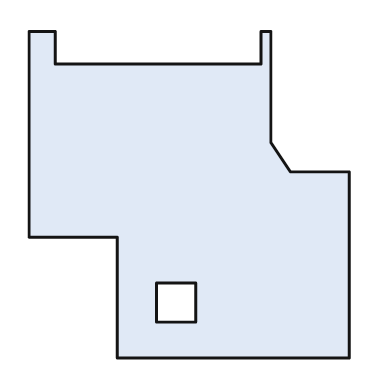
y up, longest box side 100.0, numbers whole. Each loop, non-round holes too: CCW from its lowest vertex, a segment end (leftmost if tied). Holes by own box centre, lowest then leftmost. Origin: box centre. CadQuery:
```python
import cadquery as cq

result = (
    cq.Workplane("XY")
    .moveTo(-22.0, -50.0)
    .lineTo(49.0, -50.0)
    .lineTo(49.0, 7.0)
    .lineTo(31.0, 7.0)
    .lineTo(25.0, 16.0)
    .lineTo(25.0, 50.0)
    .lineTo(22.0, 50.0)
    .lineTo(22.0, 40.0)
    .lineTo(-41.0, 40.0)
    .lineTo(-41.0, 50.0)
    .lineTo(-49.0, 50.0)
    .lineTo(-49.0, -13.0)
    .lineTo(-22.0, -13.0)
    .close()
    .moveTo(-10.0, -39.0)
    .lineTo(2.0, -39.0)
    .lineTo(2.0, -27.0)
    .lineTo(-10.0, -27.0)
    .close()
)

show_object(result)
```